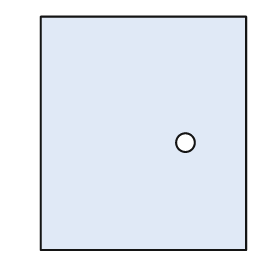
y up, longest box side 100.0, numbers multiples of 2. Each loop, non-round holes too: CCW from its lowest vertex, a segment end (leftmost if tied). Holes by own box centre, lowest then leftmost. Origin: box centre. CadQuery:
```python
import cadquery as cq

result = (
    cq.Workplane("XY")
    .moveTo(-44.0, -50.0)
    .lineTo(44.0, -50.0)
    .lineTo(44.0, 50.0)
    .lineTo(-44.0, 50.0)
    .close()
    .moveTo(18.0, -4.0)
    .circle(4.0)
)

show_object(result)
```